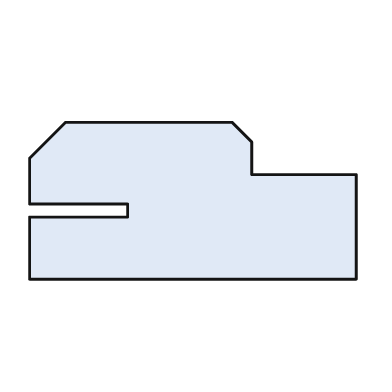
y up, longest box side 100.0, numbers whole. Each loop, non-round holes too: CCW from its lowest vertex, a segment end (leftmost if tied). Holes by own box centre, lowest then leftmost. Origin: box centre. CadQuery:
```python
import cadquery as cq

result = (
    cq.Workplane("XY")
    .moveTo(-50.0, -24.0)
    .lineTo(50.0, -24.0)
    .lineTo(50.0, 8.0)
    .lineTo(18.0, 8.0)
    .lineTo(18.0, 18.0)
    .lineTo(12.0, 24.0)
    .lineTo(-39.0, 24.0)
    .lineTo(-50.0, 13.0)
    .lineTo(-50.0, -1.0)
    .lineTo(-20.0, -1.0)
    .lineTo(-20.0, -5.0)
    .lineTo(-50.0, -5.0)
    .close()
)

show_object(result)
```